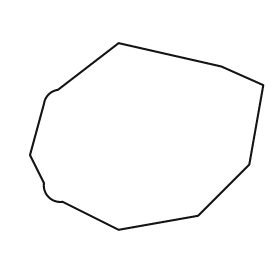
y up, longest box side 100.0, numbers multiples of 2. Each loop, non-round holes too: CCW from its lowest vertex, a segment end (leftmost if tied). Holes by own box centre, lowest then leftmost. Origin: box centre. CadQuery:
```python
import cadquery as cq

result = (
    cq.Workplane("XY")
    .moveTo(-12.0, -40.0)
    .lineTo(22.0, -34.0)
    .lineTo(44.0, -12.0)
    .lineTo(50.0, 22.0)
    .lineTo(32.0, 30.0)
    .lineTo(-12.0, 40.0)
    .lineTo(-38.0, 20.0)
    .threePointArc((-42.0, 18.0), (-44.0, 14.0))
    .lineTo(-50.0, -8.0)
    .lineTo(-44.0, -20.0)
    .threePointArc((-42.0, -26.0), (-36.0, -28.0))
    .close()
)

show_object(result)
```